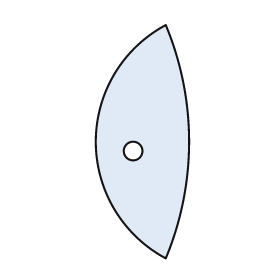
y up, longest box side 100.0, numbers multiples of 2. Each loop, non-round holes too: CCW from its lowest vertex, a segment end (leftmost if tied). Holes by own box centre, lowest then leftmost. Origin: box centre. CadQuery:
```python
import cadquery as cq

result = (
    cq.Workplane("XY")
    .moveTo(10.0, -50.0)
    .threePointArc((20.0, 0.0), (10.0, 50.0))
    .threePointArc((-20.0, 0.0), (10.0, -50.0))
    .close()
    .moveTo(-4.0, -4.0)
    .circle(4.0)
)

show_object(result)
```